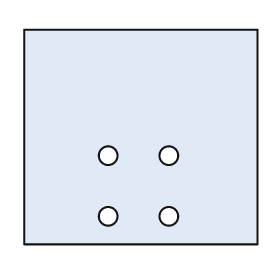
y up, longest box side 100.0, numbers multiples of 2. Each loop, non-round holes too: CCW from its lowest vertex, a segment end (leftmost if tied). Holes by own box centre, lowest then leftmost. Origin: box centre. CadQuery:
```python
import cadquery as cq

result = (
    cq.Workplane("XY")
    .moveTo(-50.0, -46.0)
    .lineTo(50.0, -46.0)
    .lineTo(50.0, 46.0)
    .lineTo(-50.0, 46.0)
    .close()
    .moveTo(-14.0, -34.0)
    .circle(4.0)
    .moveTo(12.0, -34.0)
    .circle(4.0)
    .moveTo(-14.0, -8.0)
    .circle(4.0)
    .moveTo(12.0, -8.0)
    .circle(4.0)
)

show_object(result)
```